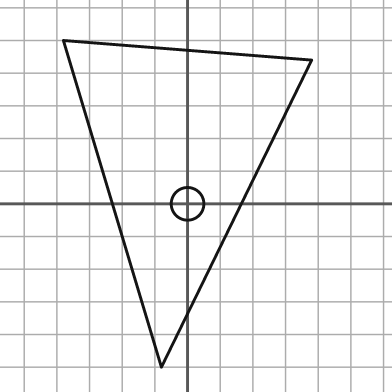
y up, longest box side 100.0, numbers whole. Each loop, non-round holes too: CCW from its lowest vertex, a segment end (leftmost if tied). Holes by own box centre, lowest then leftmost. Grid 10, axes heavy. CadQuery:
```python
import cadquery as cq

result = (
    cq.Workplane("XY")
    .moveTo(-8.0, -50.0)
    .lineTo(38.0, 44.0)
    .lineTo(-38.0, 50.0)
    .close()
    .moveTo(0.0, 0.0)
    .circle(5.0)
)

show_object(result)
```